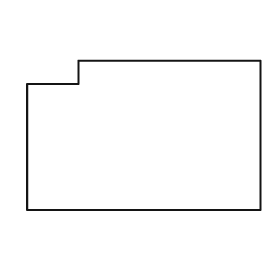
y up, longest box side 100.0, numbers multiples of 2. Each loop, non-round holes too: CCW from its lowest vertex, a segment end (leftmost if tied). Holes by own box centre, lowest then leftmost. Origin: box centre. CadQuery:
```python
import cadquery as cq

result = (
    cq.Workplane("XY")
    .moveTo(-50.0, -32.0)
    .lineTo(50.0, -32.0)
    .lineTo(50.0, 32.0)
    .lineTo(-28.0, 32.0)
    .lineTo(-28.0, 22.0)
    .lineTo(-50.0, 22.0)
    .close()
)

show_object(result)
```